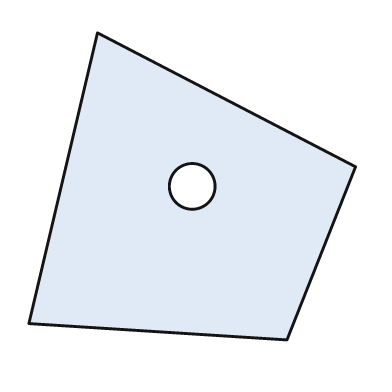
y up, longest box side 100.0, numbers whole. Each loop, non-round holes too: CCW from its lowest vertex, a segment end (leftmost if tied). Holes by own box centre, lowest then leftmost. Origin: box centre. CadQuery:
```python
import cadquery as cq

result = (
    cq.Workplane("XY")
    .moveTo(29.0, -47.0)
    .lineTo(50.0, 6.0)
    .lineTo(-29.0, 47.0)
    .lineTo(-50.0, -42.0)
    .close()
    .moveTo(0.0, 0.0)
    .circle(7.0)
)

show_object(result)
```